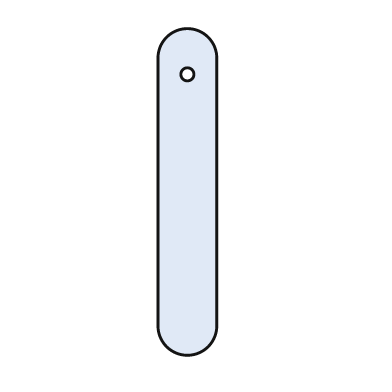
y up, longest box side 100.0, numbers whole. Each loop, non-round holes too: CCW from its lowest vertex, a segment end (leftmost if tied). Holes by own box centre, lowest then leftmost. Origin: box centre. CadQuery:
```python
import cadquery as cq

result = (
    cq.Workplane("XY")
    .moveTo(-9.0, -41.0)
    .threePointArc((0.0, -50.0), (9.0, -41.0))
    .lineTo(9.0, 41.0)
    .threePointArc((0.0, 50.0), (-9.0, 41.0))
    .close()
    .moveTo(0.0, 36.0)
    .circle(2.0)
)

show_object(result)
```